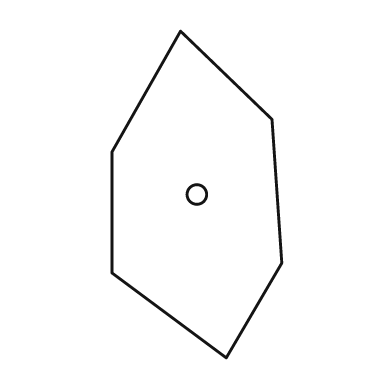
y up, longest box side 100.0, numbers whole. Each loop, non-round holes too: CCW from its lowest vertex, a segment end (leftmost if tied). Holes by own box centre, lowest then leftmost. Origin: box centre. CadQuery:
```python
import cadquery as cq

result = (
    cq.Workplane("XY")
    .moveTo(9.0, -50.0)
    .lineTo(26.0, -21.0)
    .lineTo(23.0, 23.0)
    .lineTo(-5.0, 50.0)
    .lineTo(-26.0, 13.0)
    .lineTo(-26.0, -24.0)
    .close()
    .moveTo(0.0, 0.0)
    .circle(3.0)
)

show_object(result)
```